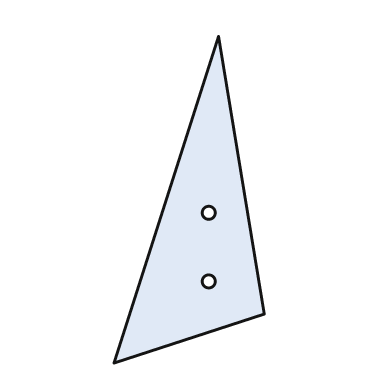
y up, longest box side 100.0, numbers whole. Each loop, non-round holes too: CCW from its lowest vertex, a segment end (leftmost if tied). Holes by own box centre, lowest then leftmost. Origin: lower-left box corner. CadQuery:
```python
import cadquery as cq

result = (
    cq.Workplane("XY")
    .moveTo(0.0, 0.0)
    .lineTo(46.0, 15.0)
    .lineTo(32.0, 100.0)
    .close()
    .moveTo(29.0, 25.0)
    .circle(2.0)
    .moveTo(29.0, 46.0)
    .circle(2.0)
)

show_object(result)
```